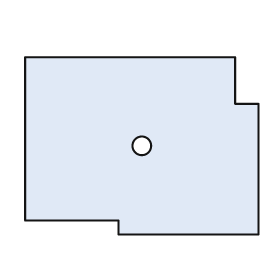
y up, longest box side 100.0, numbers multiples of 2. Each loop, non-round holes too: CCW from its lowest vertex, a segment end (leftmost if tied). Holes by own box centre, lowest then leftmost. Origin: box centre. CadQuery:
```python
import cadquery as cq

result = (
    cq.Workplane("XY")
    .moveTo(-10.0, -38.0)
    .lineTo(50.0, -38.0)
    .lineTo(50.0, 18.0)
    .lineTo(40.0, 18.0)
    .lineTo(40.0, 38.0)
    .lineTo(-50.0, 38.0)
    .lineTo(-50.0, -32.0)
    .lineTo(-10.0, -32.0)
    .close()
    .moveTo(0.0, 0.0)
    .circle(4.0)
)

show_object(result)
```